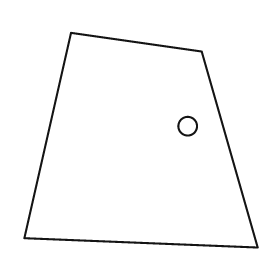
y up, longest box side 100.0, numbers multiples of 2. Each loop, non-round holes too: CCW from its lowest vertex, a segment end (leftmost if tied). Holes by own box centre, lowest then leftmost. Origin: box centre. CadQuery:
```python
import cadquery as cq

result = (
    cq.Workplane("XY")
    .moveTo(50.0, -46.0)
    .lineTo(26.0, 38.0)
    .lineTo(-30.0, 46.0)
    .lineTo(-50.0, -42.0)
    .close()
    .moveTo(20.0, 6.0)
    .circle(4.0)
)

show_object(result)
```